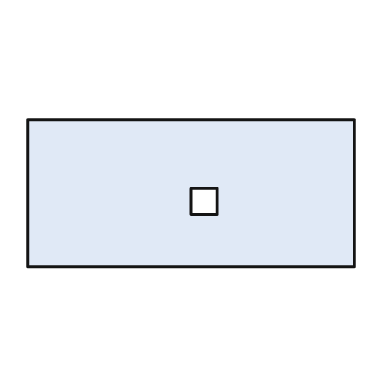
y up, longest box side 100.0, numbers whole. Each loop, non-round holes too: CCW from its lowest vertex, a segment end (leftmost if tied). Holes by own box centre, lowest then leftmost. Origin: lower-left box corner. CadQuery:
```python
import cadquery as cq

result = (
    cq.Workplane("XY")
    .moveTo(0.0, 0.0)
    .lineTo(100.0, 0.0)
    .lineTo(100.0, 45.0)
    .lineTo(0.0, 45.0)
    .close()
    .moveTo(50.0, 16.0)
    .lineTo(58.0, 16.0)
    .lineTo(58.0, 24.0)
    .lineTo(50.0, 24.0)
    .close()
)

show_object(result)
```